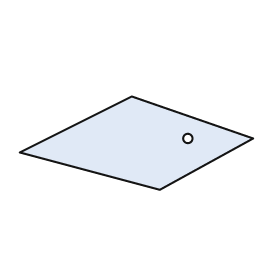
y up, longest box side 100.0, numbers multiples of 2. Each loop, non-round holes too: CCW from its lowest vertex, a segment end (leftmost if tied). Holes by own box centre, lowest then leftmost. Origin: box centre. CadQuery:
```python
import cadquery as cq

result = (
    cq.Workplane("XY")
    .moveTo(10.0, -20.0)
    .lineTo(50.0, 2.0)
    .lineTo(-2.0, 20.0)
    .lineTo(-50.0, -4.0)
    .close()
    .moveTo(22.0, 2.0)
    .circle(2.0)
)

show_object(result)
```